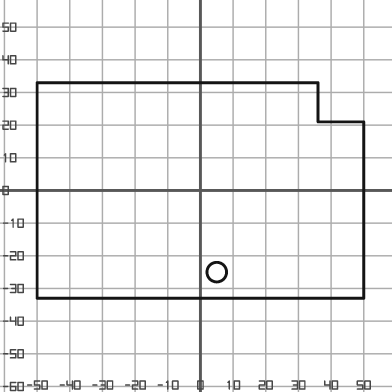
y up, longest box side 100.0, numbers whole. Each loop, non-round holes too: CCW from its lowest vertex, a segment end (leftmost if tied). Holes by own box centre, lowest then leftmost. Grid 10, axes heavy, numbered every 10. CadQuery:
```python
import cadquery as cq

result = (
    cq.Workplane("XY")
    .moveTo(-50.0, -33.0)
    .lineTo(50.0, -33.0)
    .lineTo(50.0, 21.0)
    .lineTo(36.0, 21.0)
    .lineTo(36.0, 33.0)
    .lineTo(-50.0, 33.0)
    .close()
    .moveTo(5.0, -25.0)
    .circle(3.0)
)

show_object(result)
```